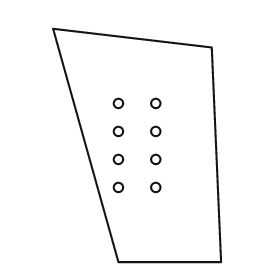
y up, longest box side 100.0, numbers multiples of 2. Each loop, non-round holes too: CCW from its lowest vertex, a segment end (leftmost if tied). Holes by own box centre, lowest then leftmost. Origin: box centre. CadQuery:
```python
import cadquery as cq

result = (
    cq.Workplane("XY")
    .moveTo(-8.0, -50.0)
    .lineTo(36.0, -50.0)
    .lineTo(32.0, 42.0)
    .lineTo(-36.0, 50.0)
    .close()
    .moveTo(-8.0, -18.0)
    .circle(2.0)
    .moveTo(8.0, -18.0)
    .circle(2.0)
    .moveTo(-8.0, -6.0)
    .circle(2.0)
    .moveTo(8.0, -6.0)
    .circle(2.0)
    .moveTo(-8.0, 6.0)
    .circle(2.0)
    .moveTo(8.0, 6.0)
    .circle(2.0)
    .moveTo(-8.0, 18.0)
    .circle(2.0)
    .moveTo(8.0, 18.0)
    .circle(2.0)
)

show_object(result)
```